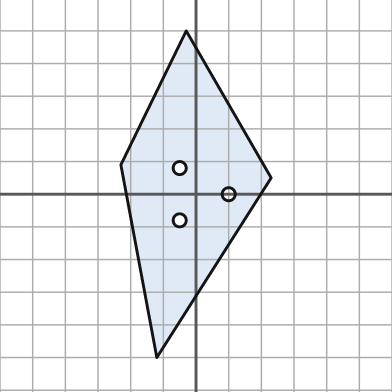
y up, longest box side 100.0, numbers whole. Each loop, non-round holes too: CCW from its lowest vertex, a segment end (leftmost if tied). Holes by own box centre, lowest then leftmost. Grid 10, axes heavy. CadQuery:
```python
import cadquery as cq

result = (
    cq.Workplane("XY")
    .moveTo(-12.0, -50.0)
    .lineTo(23.0, 5.0)
    .lineTo(-3.0, 50.0)
    .lineTo(-23.0, 9.0)
    .close()
    .moveTo(-5.0, -8.0)
    .circle(2.0)
    .moveTo(10.0, 0.0)
    .circle(2.0)
    .moveTo(-5.0, 8.0)
    .circle(2.0)
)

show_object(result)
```